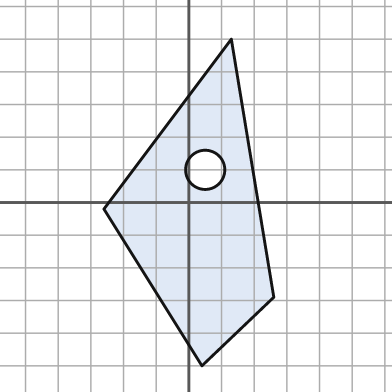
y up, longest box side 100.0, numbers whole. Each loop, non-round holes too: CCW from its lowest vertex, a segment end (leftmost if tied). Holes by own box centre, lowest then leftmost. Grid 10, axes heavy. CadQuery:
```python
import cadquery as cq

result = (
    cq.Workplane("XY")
    .moveTo(4.0, -50.0)
    .lineTo(26.0, -29.0)
    .lineTo(13.0, 50.0)
    .lineTo(-26.0, -2.0)
    .close()
    .moveTo(5.0, 10.0)
    .circle(6.0)
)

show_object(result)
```